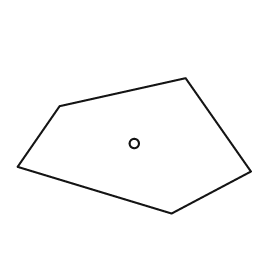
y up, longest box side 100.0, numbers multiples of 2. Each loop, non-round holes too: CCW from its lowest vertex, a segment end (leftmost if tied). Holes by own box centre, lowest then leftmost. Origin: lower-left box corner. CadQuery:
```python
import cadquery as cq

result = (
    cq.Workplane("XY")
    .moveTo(66.0, 0.0)
    .lineTo(100.0, 18.0)
    .lineTo(72.0, 58.0)
    .lineTo(18.0, 46.0)
    .lineTo(0.0, 20.0)
    .close()
    .moveTo(50.0, 30.0)
    .circle(2.0)
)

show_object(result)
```